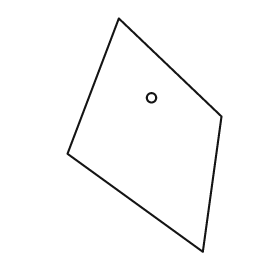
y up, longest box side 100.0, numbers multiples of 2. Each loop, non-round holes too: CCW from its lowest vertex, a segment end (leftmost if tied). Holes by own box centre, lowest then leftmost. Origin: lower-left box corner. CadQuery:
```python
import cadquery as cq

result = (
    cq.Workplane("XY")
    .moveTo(58.0, 0.0)
    .lineTo(66.0, 58.0)
    .lineTo(22.0, 100.0)
    .lineTo(0.0, 42.0)
    .close()
    .moveTo(36.0, 66.0)
    .circle(2.0)
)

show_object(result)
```